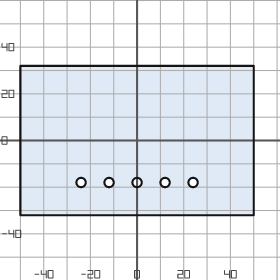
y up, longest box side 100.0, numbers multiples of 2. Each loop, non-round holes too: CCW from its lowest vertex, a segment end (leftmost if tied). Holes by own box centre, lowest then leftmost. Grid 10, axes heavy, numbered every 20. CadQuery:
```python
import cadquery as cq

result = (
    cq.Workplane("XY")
    .moveTo(-50.0, -32.0)
    .lineTo(50.0, -32.0)
    .lineTo(50.0, 32.0)
    .lineTo(-50.0, 32.0)
    .close()
    .moveTo(-24.0, -18.0)
    .circle(2.0)
    .moveTo(-12.0, -18.0)
    .circle(2.0)
    .moveTo(0.0, -18.0)
    .circle(2.0)
    .moveTo(12.0, -18.0)
    .circle(2.0)
    .moveTo(24.0, -18.0)
    .circle(2.0)
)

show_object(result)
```